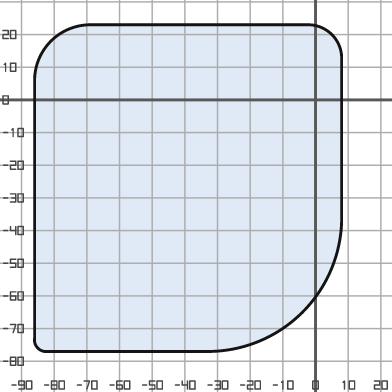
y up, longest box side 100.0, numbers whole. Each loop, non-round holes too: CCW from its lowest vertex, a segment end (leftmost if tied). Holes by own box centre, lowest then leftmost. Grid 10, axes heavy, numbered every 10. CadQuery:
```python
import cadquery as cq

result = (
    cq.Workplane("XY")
    .moveTo(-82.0, -77.0)
    .lineTo(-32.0, -77.0)
    .threePointArc((-4.0, -65.0), (8.0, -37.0))
    .lineTo(8.0, 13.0)
    .threePointArc((5.0, 20.0), (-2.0, 23.0))
    .lineTo(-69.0, 23.0)
    .threePointArc((-81.0, 18.0), (-86.0, 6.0))
    .lineTo(-86.0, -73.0)
    .threePointArc((-85.0, -76.0), (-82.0, -77.0))
    .close()
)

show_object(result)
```